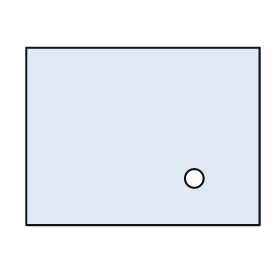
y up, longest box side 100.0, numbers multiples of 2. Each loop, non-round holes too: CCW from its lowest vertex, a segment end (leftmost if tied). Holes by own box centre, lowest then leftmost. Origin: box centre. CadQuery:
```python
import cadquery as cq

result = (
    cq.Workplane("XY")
    .moveTo(-50.0, -38.0)
    .lineTo(50.0, -38.0)
    .lineTo(50.0, 38.0)
    .lineTo(-50.0, 38.0)
    .close()
    .moveTo(22.0, -18.0)
    .circle(4.0)
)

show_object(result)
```